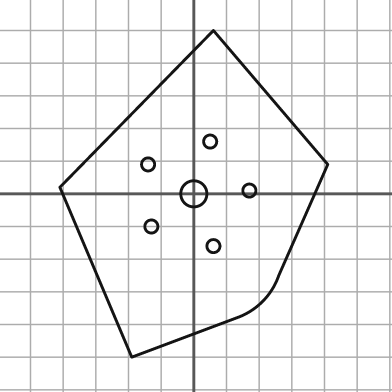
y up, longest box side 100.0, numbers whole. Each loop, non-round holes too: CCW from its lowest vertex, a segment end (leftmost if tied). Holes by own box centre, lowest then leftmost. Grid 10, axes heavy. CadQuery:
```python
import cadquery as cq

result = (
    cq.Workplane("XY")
    .moveTo(-19.0, -50.0)
    .lineTo(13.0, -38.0)
    .threePointArc((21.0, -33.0), (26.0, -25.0))
    .lineTo(41.0, 9.0)
    .lineTo(6.0, 50.0)
    .lineTo(-41.0, 2.0)
    .close()
    .moveTo(6.0, -16.0)
    .circle(2.0)
    .moveTo(-13.0, -10.0)
    .circle(2.0)
    .moveTo(0.0, 0.0)
    .circle(4.0)
    .moveTo(17.0, 1.0)
    .circle(2.0)
    .moveTo(-14.0, 9.0)
    .circle(2.0)
    .moveTo(5.0, 16.0)
    .circle(2.0)
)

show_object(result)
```